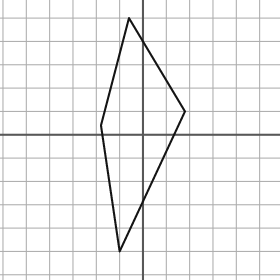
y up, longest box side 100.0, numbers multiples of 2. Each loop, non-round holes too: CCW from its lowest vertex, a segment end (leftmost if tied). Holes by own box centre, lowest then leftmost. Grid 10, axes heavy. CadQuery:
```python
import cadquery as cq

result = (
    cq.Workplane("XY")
    .moveTo(-10.0, -50.0)
    .lineTo(18.0, 10.0)
    .lineTo(-6.0, 50.0)
    .lineTo(-18.0, 4.0)
    .close()
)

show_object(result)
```